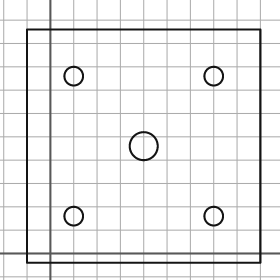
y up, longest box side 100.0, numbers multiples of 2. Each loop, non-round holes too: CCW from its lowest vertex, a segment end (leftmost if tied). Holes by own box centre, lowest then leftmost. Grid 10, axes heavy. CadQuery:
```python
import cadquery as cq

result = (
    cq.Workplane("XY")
    .moveTo(-10.0, -4.0)
    .lineTo(90.0, -4.0)
    .lineTo(90.0, 96.0)
    .lineTo(-10.0, 96.0)
    .close()
    .moveTo(10.0, 16.0)
    .circle(4.0)
    .moveTo(70.0, 16.0)
    .circle(4.0)
    .moveTo(40.0, 46.0)
    .circle(6.0)
    .moveTo(10.0, 76.0)
    .circle(4.0)
    .moveTo(70.0, 76.0)
    .circle(4.0)
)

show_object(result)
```